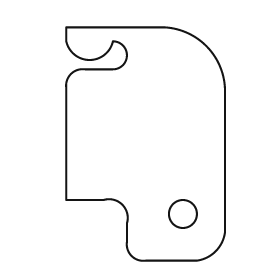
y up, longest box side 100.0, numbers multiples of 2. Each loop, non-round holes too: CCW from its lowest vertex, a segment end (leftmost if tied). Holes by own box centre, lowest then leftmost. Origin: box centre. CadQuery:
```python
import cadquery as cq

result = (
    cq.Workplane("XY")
    .moveTo(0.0, -50.0)
    .lineTo(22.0, -50.0)
    .threePointArc((30.0, -46.0), (34.0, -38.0))
    .lineTo(34.0, 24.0)
    .threePointArc((26.0, 42.0), (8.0, 50.0))
    .lineTo(-34.0, 50.0)
    .lineTo(-34.0, 44.0)
    .threePointArc((-24.0, 36.0), (-14.0, 44.0))
    .threePointArc((-8.0, 38.0), (-14.0, 32.0))
    .lineTo(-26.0, 32.0)
    .threePointArc((-32.0, 30.0), (-34.0, 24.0))
    .lineTo(-34.0, -24.0)
    .lineTo(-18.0, -24.0)
    .threePointArc((-10.0, -26.0), (-8.0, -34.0))
    .lineTo(-8.0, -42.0)
    .threePointArc((-6.0, -48.0), (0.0, -50.0))
    .close()
    .moveTo(16.0, -30.0)
    .circle(6.0)
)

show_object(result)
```